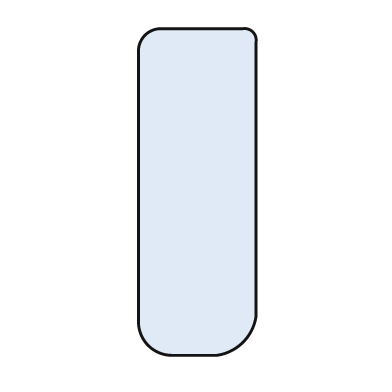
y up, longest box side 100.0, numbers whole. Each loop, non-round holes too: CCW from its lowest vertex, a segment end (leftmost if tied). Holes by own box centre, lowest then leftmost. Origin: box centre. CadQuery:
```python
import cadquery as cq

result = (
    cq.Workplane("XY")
    .moveTo(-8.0, -50.0)
    .lineTo(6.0, -50.0)
    .threePointArc((14.0, -46.0), (18.0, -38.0))
    .lineTo(18.0, 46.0)
    .threePointArc((17.0, 49.0), (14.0, 50.0))
    .lineTo(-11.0, 50.0)
    .threePointArc((-16.0, 48.0), (-18.0, 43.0))
    .lineTo(-18.0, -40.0)
    .threePointArc((-15.0, -47.0), (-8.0, -50.0))
    .close()
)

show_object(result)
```